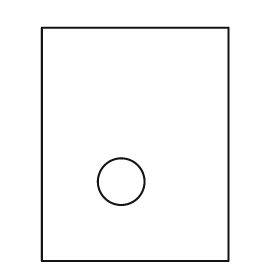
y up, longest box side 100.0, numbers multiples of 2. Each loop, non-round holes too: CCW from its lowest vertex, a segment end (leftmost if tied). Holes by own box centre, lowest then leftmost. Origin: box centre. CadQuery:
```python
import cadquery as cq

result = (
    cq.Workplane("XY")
    .moveTo(-40.0, -50.0)
    .lineTo(40.0, -50.0)
    .lineTo(40.0, 50.0)
    .lineTo(-40.0, 50.0)
    .close()
    .moveTo(-6.0, -16.0)
    .circle(10.0)
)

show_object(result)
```